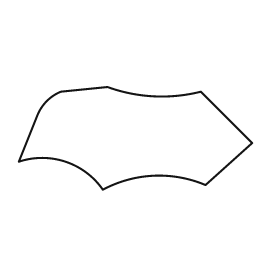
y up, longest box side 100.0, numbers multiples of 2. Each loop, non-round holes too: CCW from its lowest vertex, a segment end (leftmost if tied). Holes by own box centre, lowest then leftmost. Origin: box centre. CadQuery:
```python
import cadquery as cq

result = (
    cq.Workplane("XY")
    .moveTo(-14.0, -22.0)
    .threePointArc((8.0, -16.0), (30.0, -20.0))
    .lineTo(50.0, -2.0)
    .lineTo(28.0, 20.0)
    .threePointArc((8.0, 18.0), (-12.0, 22.0))
    .lineTo(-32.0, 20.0)
    .threePointArc((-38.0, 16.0), (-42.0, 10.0))
    .lineTo(-50.0, -10.0)
    .threePointArc((-30.0, -10.0), (-14.0, -22.0))
    .close()
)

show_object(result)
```